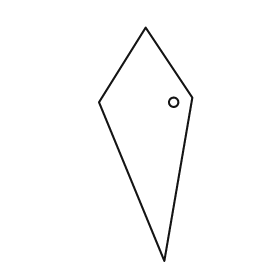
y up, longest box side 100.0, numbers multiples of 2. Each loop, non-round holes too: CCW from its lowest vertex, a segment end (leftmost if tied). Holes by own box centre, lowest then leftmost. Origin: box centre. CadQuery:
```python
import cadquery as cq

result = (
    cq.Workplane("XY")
    .moveTo(8.0, -50.0)
    .lineTo(20.0, 20.0)
    .lineTo(0.0, 50.0)
    .lineTo(-20.0, 18.0)
    .close()
    .moveTo(12.0, 18.0)
    .circle(2.0)
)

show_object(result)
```